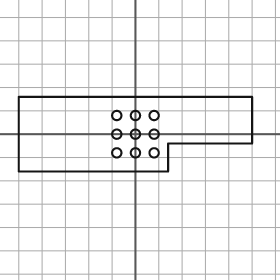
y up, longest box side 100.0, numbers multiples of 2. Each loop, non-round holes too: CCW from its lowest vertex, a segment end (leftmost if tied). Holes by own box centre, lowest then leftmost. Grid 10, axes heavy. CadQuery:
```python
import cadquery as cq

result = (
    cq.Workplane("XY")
    .moveTo(-50.0, -16.0)
    .lineTo(14.0, -16.0)
    .lineTo(14.0, -4.0)
    .lineTo(50.0, -4.0)
    .lineTo(50.0, 16.0)
    .lineTo(-50.0, 16.0)
    .close()
    .moveTo(-8.0, -8.0)
    .circle(2.0)
    .moveTo(0.0, -8.0)
    .circle(2.0)
    .moveTo(8.0, -8.0)
    .circle(2.0)
    .moveTo(-8.0, 0.0)
    .circle(2.0)
    .moveTo(0.0, 0.0)
    .circle(2.0)
    .moveTo(8.0, 0.0)
    .circle(2.0)
    .moveTo(-8.0, 8.0)
    .circle(2.0)
    .moveTo(0.0, 8.0)
    .circle(2.0)
    .moveTo(8.0, 8.0)
    .circle(2.0)
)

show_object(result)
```